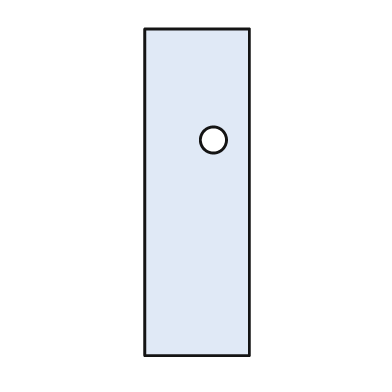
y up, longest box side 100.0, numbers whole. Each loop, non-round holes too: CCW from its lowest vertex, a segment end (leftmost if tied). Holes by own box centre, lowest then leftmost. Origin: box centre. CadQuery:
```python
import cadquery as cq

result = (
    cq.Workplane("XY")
    .moveTo(-16.0, -50.0)
    .lineTo(16.0, -50.0)
    .lineTo(16.0, 50.0)
    .lineTo(-16.0, 50.0)
    .close()
    .moveTo(5.0, 16.0)
    .circle(4.0)
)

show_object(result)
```